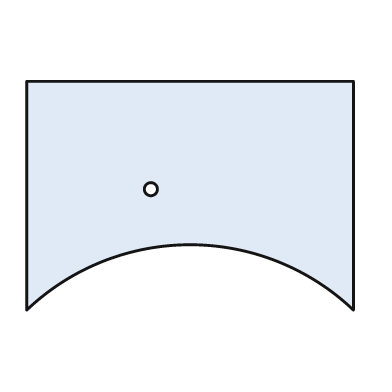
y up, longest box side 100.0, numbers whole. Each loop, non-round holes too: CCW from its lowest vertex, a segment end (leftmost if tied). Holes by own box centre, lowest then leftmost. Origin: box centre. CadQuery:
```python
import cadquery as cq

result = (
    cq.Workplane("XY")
    .moveTo(-50.0, -35.0)
    .threePointArc((0.0, -15.0), (50.0, -35.0))
    .lineTo(50.0, 35.0)
    .lineTo(-50.0, 35.0)
    .close()
    .moveTo(-12.0, 2.0)
    .circle(2.0)
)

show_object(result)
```